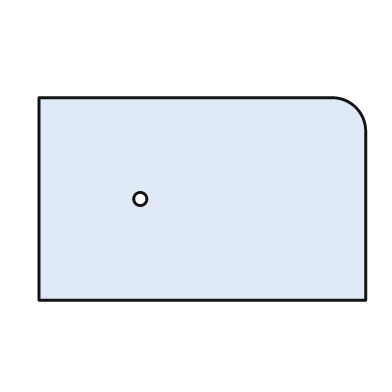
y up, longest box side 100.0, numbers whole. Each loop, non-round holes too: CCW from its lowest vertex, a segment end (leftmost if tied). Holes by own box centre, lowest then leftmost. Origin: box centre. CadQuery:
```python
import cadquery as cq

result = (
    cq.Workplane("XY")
    .moveTo(-50.0, -31.0)
    .lineTo(50.0, -31.0)
    .lineTo(50.0, 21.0)
    .threePointArc((47.0, 28.0), (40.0, 31.0))
    .lineTo(-50.0, 31.0)
    .close()
    .moveTo(-19.0, 0.0)
    .circle(2.0)
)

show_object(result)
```